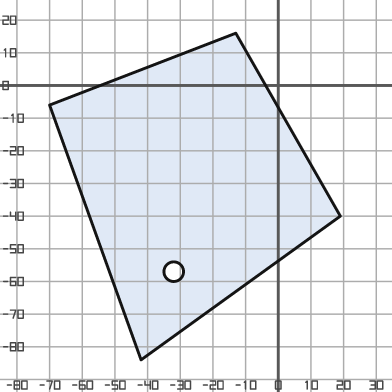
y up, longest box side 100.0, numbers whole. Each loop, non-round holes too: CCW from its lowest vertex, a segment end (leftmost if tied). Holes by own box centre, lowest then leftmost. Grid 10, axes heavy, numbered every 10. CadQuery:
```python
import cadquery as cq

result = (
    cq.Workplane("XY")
    .moveTo(-42.0, -84.0)
    .lineTo(19.0, -40.0)
    .lineTo(-13.0, 16.0)
    .lineTo(-70.0, -6.0)
    .close()
    .moveTo(-32.0, -57.0)
    .circle(3.0)
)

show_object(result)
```